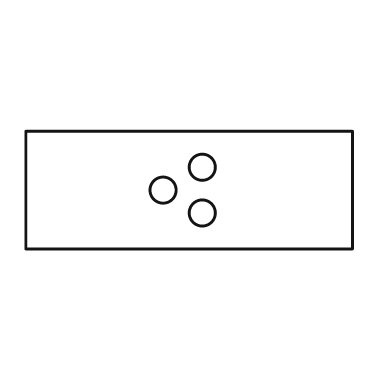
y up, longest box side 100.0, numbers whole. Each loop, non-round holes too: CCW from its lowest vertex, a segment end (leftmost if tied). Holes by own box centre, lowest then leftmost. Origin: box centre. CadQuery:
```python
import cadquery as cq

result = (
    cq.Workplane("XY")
    .moveTo(-50.0, -18.0)
    .lineTo(50.0, -18.0)
    .lineTo(50.0, 18.0)
    .lineTo(-50.0, 18.0)
    .close()
    .moveTo(4.0, -7.0)
    .circle(4.0)
    .moveTo(-8.0, 0.0)
    .circle(4.0)
    .moveTo(4.0, 7.0)
    .circle(4.0)
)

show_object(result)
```